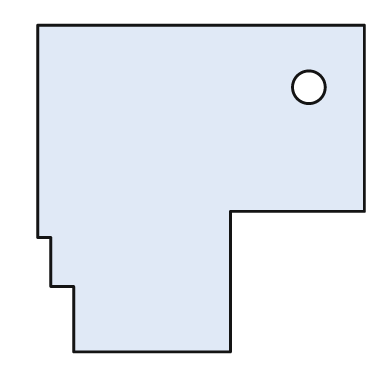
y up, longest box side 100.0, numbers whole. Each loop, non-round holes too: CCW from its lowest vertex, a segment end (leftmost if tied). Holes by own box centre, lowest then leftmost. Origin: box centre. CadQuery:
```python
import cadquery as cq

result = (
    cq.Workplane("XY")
    .moveTo(-39.0, -50.0)
    .lineTo(9.0, -50.0)
    .lineTo(9.0, -7.0)
    .lineTo(50.0, -7.0)
    .lineTo(50.0, 50.0)
    .lineTo(-50.0, 50.0)
    .lineTo(-50.0, -15.0)
    .lineTo(-46.0, -15.0)
    .lineTo(-46.0, -30.0)
    .lineTo(-39.0, -30.0)
    .close()
    .moveTo(33.0, 31.0)
    .circle(5.0)
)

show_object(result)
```